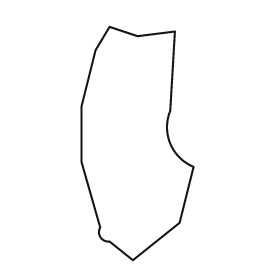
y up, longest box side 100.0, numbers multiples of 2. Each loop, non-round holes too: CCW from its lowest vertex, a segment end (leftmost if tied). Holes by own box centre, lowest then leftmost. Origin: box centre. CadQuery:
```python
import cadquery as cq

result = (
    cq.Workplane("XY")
    .moveTo(-2.0, -50.0)
    .lineTo(18.0, -34.0)
    .lineTo(24.0, -10.0)
    .threePointArc((14.0, 0.0), (14.0, 14.0))
    .lineTo(16.0, 48.0)
    .lineTo(0.0, 46.0)
    .lineTo(-12.0, 50.0)
    .lineTo(-18.0, 40.0)
    .lineTo(-24.0, 16.0)
    .lineTo(-24.0, -8.0)
    .lineTo(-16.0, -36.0)
    .threePointArc((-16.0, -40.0), (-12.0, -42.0))
    .close()
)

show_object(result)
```